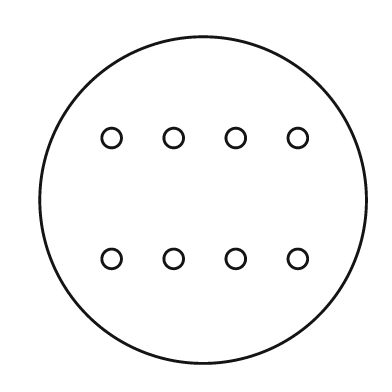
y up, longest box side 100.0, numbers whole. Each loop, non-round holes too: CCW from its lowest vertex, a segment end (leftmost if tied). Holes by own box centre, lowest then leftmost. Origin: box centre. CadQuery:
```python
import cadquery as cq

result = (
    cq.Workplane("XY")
    .moveTo(0.0, 0.0)
    .circle(50.0)
    .moveTo(-28.0, -18.0)
    .circle(3.0)
    .moveTo(-9.0, -18.0)
    .circle(3.0)
    .moveTo(10.0, -18.0)
    .circle(3.0)
    .moveTo(29.0, -18.0)
    .circle(3.0)
    .moveTo(-28.0, 19.0)
    .circle(3.0)
    .moveTo(-9.0, 19.0)
    .circle(3.0)
    .moveTo(10.0, 19.0)
    .circle(3.0)
    .moveTo(29.0, 19.0)
    .circle(3.0)
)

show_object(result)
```